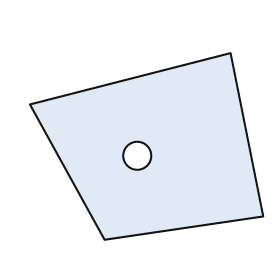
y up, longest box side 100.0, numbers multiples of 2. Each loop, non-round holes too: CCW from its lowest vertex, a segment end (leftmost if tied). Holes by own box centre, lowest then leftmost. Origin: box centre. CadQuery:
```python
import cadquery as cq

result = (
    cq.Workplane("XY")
    .moveTo(-18.0, -40.0)
    .lineTo(50.0, -30.0)
    .lineTo(36.0, 40.0)
    .lineTo(-50.0, 18.0)
    .close()
    .moveTo(-4.0, -4.0)
    .circle(6.0)
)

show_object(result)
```